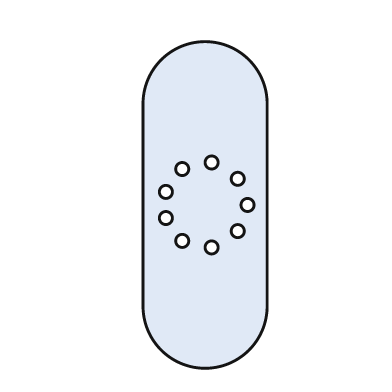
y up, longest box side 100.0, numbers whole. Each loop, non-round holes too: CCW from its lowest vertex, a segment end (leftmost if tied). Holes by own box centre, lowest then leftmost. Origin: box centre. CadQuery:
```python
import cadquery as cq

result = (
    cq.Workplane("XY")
    .moveTo(-19.0, -31.0)
    .threePointArc((0.0, -50.0), (19.0, -31.0))
    .lineTo(19.0, 31.0)
    .threePointArc((0.0, 50.0), (-19.0, 31.0))
    .close()
    .moveTo(2.0, -13.0)
    .circle(2.0)
    .moveTo(-7.0, -11.0)
    .circle(2.0)
    .moveTo(10.0, -8.0)
    .circle(2.0)
    .moveTo(-12.0, -4.0)
    .circle(2.0)
    .moveTo(13.0, 0.0)
    .circle(2.0)
    .moveTo(-12.0, 4.0)
    .circle(2.0)
    .moveTo(10.0, 8.0)
    .circle(2.0)
    .moveTo(-7.0, 11.0)
    .circle(2.0)
    .moveTo(2.0, 13.0)
    .circle(2.0)
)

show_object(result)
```